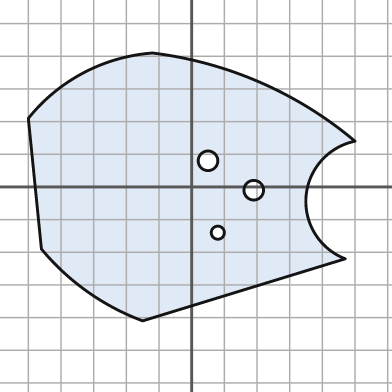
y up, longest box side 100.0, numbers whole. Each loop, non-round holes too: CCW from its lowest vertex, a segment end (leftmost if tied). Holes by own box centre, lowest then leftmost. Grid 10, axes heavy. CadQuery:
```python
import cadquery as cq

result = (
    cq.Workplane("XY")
    .moveTo(-15.0, -41.0)
    .lineTo(47.0, -22.0)
    .threePointArc((35.0, -3.0), (50.0, 14.0))
    .threePointArc((21.0, 32.0), (-12.0, 41.0))
    .threePointArc((-33.0, 35.0), (-50.0, 21.0))
    .lineTo(-46.0, -19.0)
    .threePointArc((-32.0, -32.0), (-15.0, -41.0))
    .close()
    .moveTo(8.0, -14.0)
    .circle(2.0)
    .moveTo(19.0, -1.0)
    .circle(3.0)
    .moveTo(5.0, 8.0)
    .circle(3.0)
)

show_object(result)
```